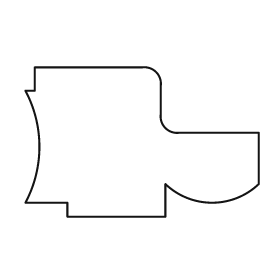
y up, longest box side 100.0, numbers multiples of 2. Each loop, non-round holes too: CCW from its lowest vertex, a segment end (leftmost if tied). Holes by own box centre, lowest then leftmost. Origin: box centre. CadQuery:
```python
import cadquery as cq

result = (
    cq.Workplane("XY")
    .moveTo(-32.0, -32.0)
    .lineTo(10.0, -32.0)
    .lineTo(10.0, -18.0)
    .threePointArc((30.0, -26.0), (50.0, -18.0))
    .lineTo(50.0, 4.0)
    .lineTo(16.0, 4.0)
    .threePointArc((10.0, 6.0), (8.0, 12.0))
    .lineTo(8.0, 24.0)
    .threePointArc((6.0, 30.0), (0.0, 32.0))
    .lineTo(-46.0, 32.0)
    .lineTo(-46.0, 22.0)
    .lineTo(-50.0, 22.0)
    .threePointArc((-44.0, -2.0), (-50.0, -26.0))
    .lineTo(-32.0, -26.0)
    .close()
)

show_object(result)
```